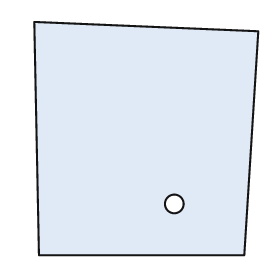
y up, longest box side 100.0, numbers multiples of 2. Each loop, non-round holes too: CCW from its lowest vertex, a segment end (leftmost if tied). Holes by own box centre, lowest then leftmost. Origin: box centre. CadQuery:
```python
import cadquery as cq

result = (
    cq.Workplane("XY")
    .moveTo(-46.0, -50.0)
    .lineTo(42.0, -50.0)
    .lineTo(48.0, 46.0)
    .lineTo(-48.0, 50.0)
    .close()
    .moveTo(12.0, -28.0)
    .circle(4.0)
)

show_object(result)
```